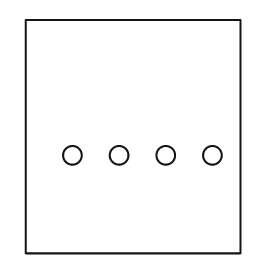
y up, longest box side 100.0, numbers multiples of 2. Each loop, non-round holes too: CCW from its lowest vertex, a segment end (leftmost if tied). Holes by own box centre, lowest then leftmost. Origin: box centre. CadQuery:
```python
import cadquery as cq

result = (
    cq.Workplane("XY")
    .moveTo(-46.0, -50.0)
    .lineTo(46.0, -50.0)
    .lineTo(46.0, 50.0)
    .lineTo(-46.0, 50.0)
    .close()
    .moveTo(-26.0, -8.0)
    .circle(4.0)
    .moveTo(-6.0, -8.0)
    .circle(4.0)
    .moveTo(14.0, -8.0)
    .circle(4.0)
    .moveTo(34.0, -8.0)
    .circle(4.0)
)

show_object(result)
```